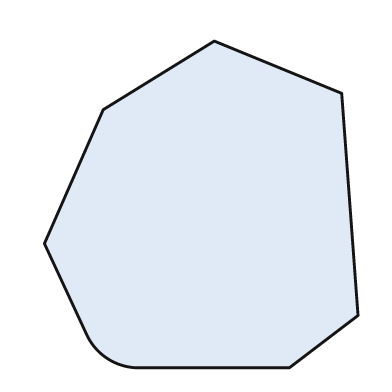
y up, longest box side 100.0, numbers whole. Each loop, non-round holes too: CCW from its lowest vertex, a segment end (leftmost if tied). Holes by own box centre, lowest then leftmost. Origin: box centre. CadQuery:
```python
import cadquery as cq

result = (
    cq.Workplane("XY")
    .moveTo(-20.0, -50.0)
    .lineTo(27.0, -50.0)
    .lineTo(48.0, -34.0)
    .lineTo(43.0, 34.0)
    .lineTo(4.0, 50.0)
    .lineTo(-30.0, 29.0)
    .lineTo(-48.0, -12.0)
    .lineTo(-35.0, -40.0)
    .threePointArc((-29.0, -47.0), (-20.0, -50.0))
    .close()
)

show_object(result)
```